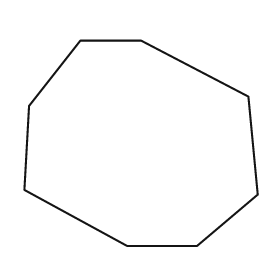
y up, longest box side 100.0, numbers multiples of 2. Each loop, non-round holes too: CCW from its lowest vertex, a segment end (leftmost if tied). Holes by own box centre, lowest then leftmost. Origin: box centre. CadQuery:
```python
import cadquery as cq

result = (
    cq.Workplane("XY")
    .moveTo(-6.0, -44.0)
    .lineTo(24.0, -44.0)
    .lineTo(50.0, -22.0)
    .lineTo(46.0, 20.0)
    .lineTo(0.0, 44.0)
    .lineTo(-26.0, 44.0)
    .lineTo(-48.0, 16.0)
    .lineTo(-50.0, -20.0)
    .close()
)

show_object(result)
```